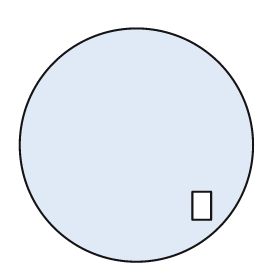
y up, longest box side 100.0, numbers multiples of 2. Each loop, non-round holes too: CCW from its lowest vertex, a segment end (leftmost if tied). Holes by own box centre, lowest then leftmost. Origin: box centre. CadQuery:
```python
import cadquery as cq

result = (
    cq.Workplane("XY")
    .moveTo(0.0, 0.0)
    .circle(50.0)
    .moveTo(24.0, -32.0)
    .lineTo(32.0, -32.0)
    .lineTo(32.0, -20.0)
    .lineTo(24.0, -20.0)
    .close()
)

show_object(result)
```